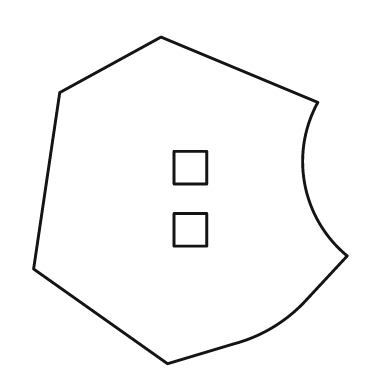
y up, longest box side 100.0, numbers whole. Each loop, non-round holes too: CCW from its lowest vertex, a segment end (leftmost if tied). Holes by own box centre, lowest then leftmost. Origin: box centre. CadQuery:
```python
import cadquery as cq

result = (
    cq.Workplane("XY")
    .moveTo(-7.0, -50.0)
    .lineTo(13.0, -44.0)
    .threePointArc((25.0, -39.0), (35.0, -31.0))
    .lineTo(48.0, -17.0)
    .threePointArc((35.0, 5.0), (39.0, 30.0))
    .lineTo(-9.0, 50.0)
    .lineTo(-40.0, 33.0)
    .lineTo(-48.0, -21.0)
    .close()
    .moveTo(-5.0, -14.0)
    .lineTo(5.0, -14.0)
    .lineTo(5.0, -4.0)
    .lineTo(-5.0, -4.0)
    .close()
    .moveTo(-5.0, 5.0)
    .lineTo(5.0, 5.0)
    .lineTo(5.0, 15.0)
    .lineTo(-5.0, 15.0)
    .close()
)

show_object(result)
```